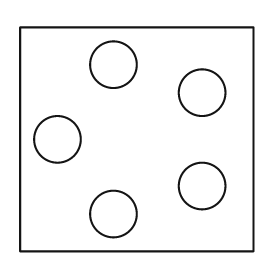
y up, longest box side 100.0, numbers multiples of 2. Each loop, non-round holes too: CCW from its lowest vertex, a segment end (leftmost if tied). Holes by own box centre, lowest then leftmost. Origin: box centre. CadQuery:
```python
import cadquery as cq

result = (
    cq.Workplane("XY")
    .moveTo(-50.0, -48.0)
    .lineTo(50.0, -48.0)
    .lineTo(50.0, 48.0)
    .lineTo(-50.0, 48.0)
    .close()
    .moveTo(-10.0, -32.0)
    .circle(10.0)
    .moveTo(28.0, -20.0)
    .circle(10.0)
    .moveTo(-34.0, 0.0)
    .circle(10.0)
    .moveTo(28.0, 20.0)
    .circle(10.0)
    .moveTo(-10.0, 32.0)
    .circle(10.0)
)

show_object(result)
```